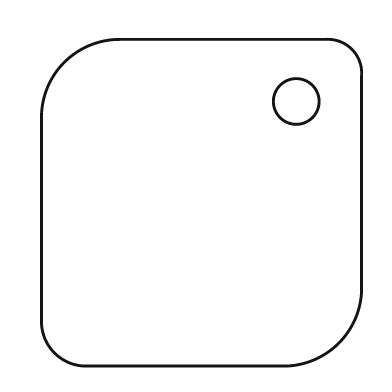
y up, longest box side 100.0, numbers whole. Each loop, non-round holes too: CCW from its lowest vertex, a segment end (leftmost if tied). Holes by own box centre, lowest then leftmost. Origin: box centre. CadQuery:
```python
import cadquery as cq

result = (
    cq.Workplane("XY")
    .moveTo(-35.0, -50.0)
    .lineTo(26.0, -50.0)
    .threePointArc((42.0, -43.0), (49.0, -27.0))
    .lineTo(49.0, 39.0)
    .threePointArc((46.0, 47.0), (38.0, 50.0))
    .lineTo(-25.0, 50.0)
    .threePointArc((-42.0, 43.0), (-49.0, 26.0))
    .lineTo(-49.0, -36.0)
    .threePointArc((-45.0, -46.0), (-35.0, -50.0))
    .close()
    .moveTo(29.0, 31.0)
    .circle(7.0)
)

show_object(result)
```